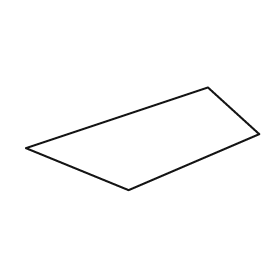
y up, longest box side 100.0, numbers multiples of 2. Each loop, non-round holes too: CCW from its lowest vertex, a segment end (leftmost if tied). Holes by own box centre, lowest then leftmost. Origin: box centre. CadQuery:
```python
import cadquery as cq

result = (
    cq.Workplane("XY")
    .moveTo(-6.0, -22.0)
    .lineTo(50.0, 2.0)
    .lineTo(28.0, 22.0)
    .lineTo(-50.0, -4.0)
    .close()
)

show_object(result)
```